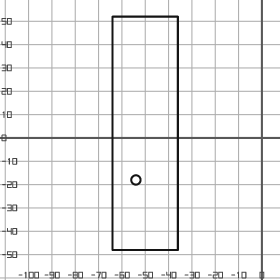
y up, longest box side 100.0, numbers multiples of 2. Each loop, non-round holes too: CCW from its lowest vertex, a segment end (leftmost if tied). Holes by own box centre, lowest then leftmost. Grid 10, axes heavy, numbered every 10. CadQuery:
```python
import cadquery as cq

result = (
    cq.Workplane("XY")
    .moveTo(-64.0, -48.0)
    .lineTo(-36.0, -48.0)
    .lineTo(-36.0, 52.0)
    .lineTo(-64.0, 52.0)
    .close()
    .moveTo(-54.0, -18.0)
    .circle(2.0)
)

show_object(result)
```